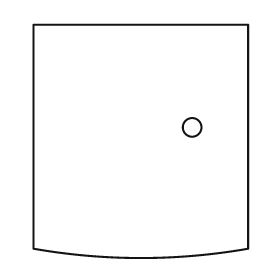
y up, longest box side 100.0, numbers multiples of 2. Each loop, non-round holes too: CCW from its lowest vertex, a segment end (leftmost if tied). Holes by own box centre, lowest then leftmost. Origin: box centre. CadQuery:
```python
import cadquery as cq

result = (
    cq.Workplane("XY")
    .moveTo(-46.0, -46.0)
    .threePointArc((0.0, -50.0), (46.0, -46.0))
    .lineTo(46.0, 50.0)
    .lineTo(-46.0, 50.0)
    .close()
    .moveTo(22.0, 6.0)
    .circle(4.0)
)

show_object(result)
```